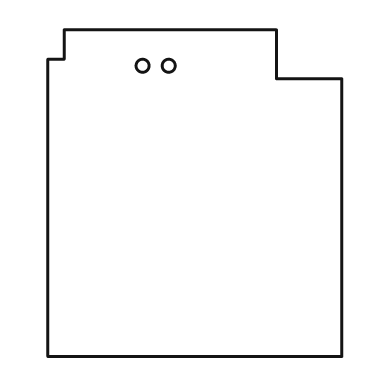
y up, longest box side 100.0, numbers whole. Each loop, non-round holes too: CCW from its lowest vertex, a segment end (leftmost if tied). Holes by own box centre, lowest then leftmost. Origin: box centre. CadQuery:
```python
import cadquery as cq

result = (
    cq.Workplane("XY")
    .moveTo(-45.0, -50.0)
    .lineTo(45.0, -50.0)
    .lineTo(45.0, 35.0)
    .lineTo(25.0, 35.0)
    .lineTo(25.0, 50.0)
    .lineTo(-40.0, 50.0)
    .lineTo(-40.0, 41.0)
    .lineTo(-45.0, 41.0)
    .close()
    .moveTo(-16.0, 39.0)
    .circle(2.0)
    .moveTo(-8.0, 39.0)
    .circle(2.0)
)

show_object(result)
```